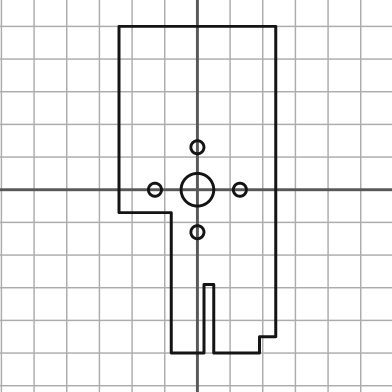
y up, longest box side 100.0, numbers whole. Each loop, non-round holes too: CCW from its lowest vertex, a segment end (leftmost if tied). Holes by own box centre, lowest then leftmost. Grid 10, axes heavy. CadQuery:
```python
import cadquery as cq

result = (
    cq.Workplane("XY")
    .moveTo(-8.0, -50.0)
    .lineTo(2.0, -50.0)
    .lineTo(2.0, -29.0)
    .lineTo(5.0, -29.0)
    .lineTo(5.0, -50.0)
    .lineTo(19.0, -50.0)
    .lineTo(19.0, -45.0)
    .lineTo(24.0, -45.0)
    .lineTo(24.0, 50.0)
    .lineTo(-24.0, 50.0)
    .lineTo(-24.0, -7.0)
    .lineTo(-8.0, -7.0)
    .close()
    .moveTo(0.0, -13.0)
    .circle(2.0)
    .moveTo(-13.0, 0.0)
    .circle(2.0)
    .moveTo(0.0, 0.0)
    .circle(5.0)
    .moveTo(13.0, 0.0)
    .circle(2.0)
    .moveTo(0.0, 13.0)
    .circle(2.0)
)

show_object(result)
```